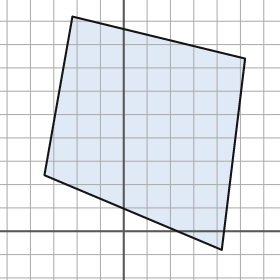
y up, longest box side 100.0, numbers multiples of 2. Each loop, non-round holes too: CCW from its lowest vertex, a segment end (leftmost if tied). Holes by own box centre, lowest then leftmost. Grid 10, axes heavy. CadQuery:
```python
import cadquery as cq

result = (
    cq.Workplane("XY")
    .moveTo(42.0, -8.0)
    .lineTo(52.0, 74.0)
    .lineTo(-22.0, 92.0)
    .lineTo(-34.0, 24.0)
    .close()
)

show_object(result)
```